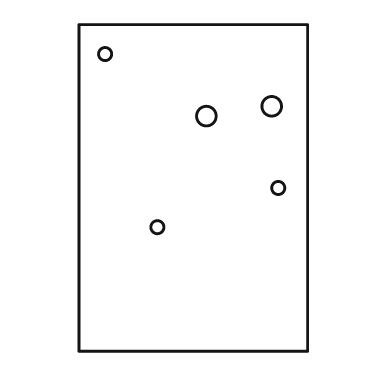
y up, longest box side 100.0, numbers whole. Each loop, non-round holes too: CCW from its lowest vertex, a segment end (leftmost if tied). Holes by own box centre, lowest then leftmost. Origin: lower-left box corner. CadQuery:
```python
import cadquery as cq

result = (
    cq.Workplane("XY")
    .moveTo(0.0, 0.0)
    .lineTo(70.0, 0.0)
    .lineTo(70.0, 100.0)
    .lineTo(0.0, 100.0)
    .close()
    .moveTo(24.0, 38.0)
    .circle(2.0)
    .moveTo(61.0, 50.0)
    .circle(2.0)
    .moveTo(39.0, 72.0)
    .circle(3.0)
    .moveTo(59.0, 75.0)
    .circle(3.0)
    .moveTo(8.0, 91.0)
    .circle(2.0)
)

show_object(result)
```